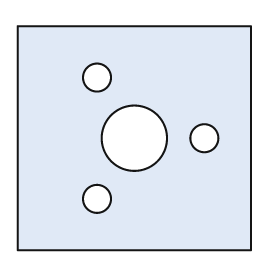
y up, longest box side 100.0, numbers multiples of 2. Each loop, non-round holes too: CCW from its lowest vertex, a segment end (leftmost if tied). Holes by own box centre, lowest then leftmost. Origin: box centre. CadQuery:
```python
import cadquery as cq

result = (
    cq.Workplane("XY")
    .moveTo(-50.0, -48.0)
    .lineTo(50.0, -48.0)
    .lineTo(50.0, 48.0)
    .lineTo(-50.0, 48.0)
    .close()
    .moveTo(-16.0, -26.0)
    .circle(6.0)
    .moveTo(0.0, 0.0)
    .circle(14.0)
    .moveTo(30.0, 0.0)
    .circle(6.0)
    .moveTo(-16.0, 26.0)
    .circle(6.0)
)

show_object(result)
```